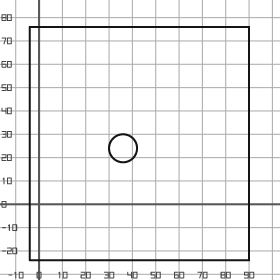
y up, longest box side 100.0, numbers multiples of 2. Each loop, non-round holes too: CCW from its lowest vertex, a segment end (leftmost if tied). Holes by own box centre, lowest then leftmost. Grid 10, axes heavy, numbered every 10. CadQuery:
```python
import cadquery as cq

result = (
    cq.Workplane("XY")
    .moveTo(-4.0, -24.0)
    .lineTo(90.0, -24.0)
    .lineTo(90.0, 76.0)
    .lineTo(-4.0, 76.0)
    .close()
    .moveTo(36.0, 24.0)
    .circle(6.0)
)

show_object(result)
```